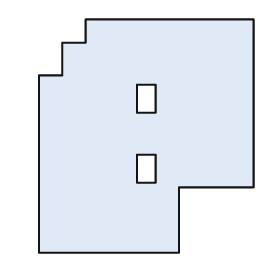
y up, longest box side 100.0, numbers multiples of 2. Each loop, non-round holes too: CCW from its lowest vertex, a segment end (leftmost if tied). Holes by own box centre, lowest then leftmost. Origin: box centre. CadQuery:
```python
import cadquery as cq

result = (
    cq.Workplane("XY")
    .moveTo(-46.0, -50.0)
    .lineTo(14.0, -50.0)
    .lineTo(14.0, -22.0)
    .lineTo(46.0, -22.0)
    .lineTo(46.0, 50.0)
    .lineTo(-26.0, 50.0)
    .lineTo(-26.0, 40.0)
    .lineTo(-36.0, 40.0)
    .lineTo(-36.0, 26.0)
    .lineTo(-46.0, 26.0)
    .close()
    .moveTo(-4.0, -20.0)
    .lineTo(4.0, -20.0)
    .lineTo(4.0, -8.0)
    .lineTo(-4.0, -8.0)
    .close()
    .moveTo(-4.0, 10.0)
    .lineTo(4.0, 10.0)
    .lineTo(4.0, 22.0)
    .lineTo(-4.0, 22.0)
    .close()
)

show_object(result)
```